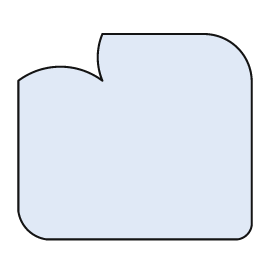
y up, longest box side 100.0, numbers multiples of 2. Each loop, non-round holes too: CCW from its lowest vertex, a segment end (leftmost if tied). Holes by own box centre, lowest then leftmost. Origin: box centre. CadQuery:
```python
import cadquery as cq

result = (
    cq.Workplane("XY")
    .moveTo(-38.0, -44.0)
    .lineTo(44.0, -44.0)
    .threePointArc((48.0, -42.0), (50.0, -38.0))
    .lineTo(50.0, 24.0)
    .threePointArc((44.0, 38.0), (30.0, 44.0))
    .lineTo(-14.0, 44.0)
    .threePointArc((-16.0, 34.0), (-14.0, 24.0))
    .threePointArc((-32.0, 30.0), (-50.0, 24.0))
    .lineTo(-50.0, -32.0)
    .threePointArc((-46.0, -40.0), (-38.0, -44.0))
    .close()
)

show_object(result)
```